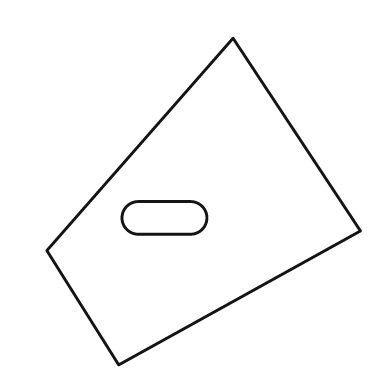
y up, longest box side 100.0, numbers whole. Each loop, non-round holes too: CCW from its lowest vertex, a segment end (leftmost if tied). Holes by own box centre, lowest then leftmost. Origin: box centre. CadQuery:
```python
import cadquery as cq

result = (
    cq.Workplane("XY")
    .moveTo(-26.0, -50.0)
    .lineTo(48.0, -9.0)
    .lineTo(9.0, 50.0)
    .lineTo(-48.0, -15.0)
    .close()
    .moveTo(-20.0, -10.0)
    .lineTo(-4.0, -10.0)
    .threePointArc((1.0, -5.0), (-4.0, 0.0))
    .lineTo(-20.0, 0.0)
    .threePointArc((-25.0, -5.0), (-20.0, -10.0))
    .close()
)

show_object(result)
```